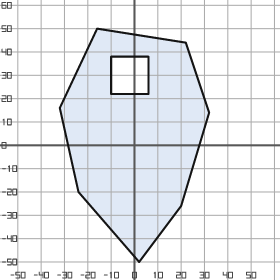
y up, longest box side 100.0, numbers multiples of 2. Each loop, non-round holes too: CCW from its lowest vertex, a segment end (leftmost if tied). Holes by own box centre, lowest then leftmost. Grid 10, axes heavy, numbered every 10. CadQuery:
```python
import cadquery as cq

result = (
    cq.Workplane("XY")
    .moveTo(2.0, -50.0)
    .lineTo(20.0, -26.0)
    .lineTo(32.0, 14.0)
    .lineTo(22.0, 44.0)
    .lineTo(-16.0, 50.0)
    .lineTo(-32.0, 16.0)
    .lineTo(-24.0, -20.0)
    .close()
    .moveTo(-10.0, 22.0)
    .lineTo(6.0, 22.0)
    .lineTo(6.0, 38.0)
    .lineTo(-10.0, 38.0)
    .close()
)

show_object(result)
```